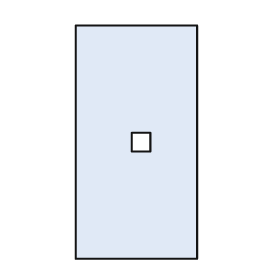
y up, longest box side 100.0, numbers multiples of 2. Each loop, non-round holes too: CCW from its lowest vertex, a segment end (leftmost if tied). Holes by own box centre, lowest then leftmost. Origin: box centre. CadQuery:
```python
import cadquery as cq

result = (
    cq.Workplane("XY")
    .moveTo(-26.0, -50.0)
    .lineTo(26.0, -50.0)
    .lineTo(26.0, 50.0)
    .lineTo(-26.0, 50.0)
    .close()
    .moveTo(-2.0, -4.0)
    .lineTo(6.0, -4.0)
    .lineTo(6.0, 4.0)
    .lineTo(-2.0, 4.0)
    .close()
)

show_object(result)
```